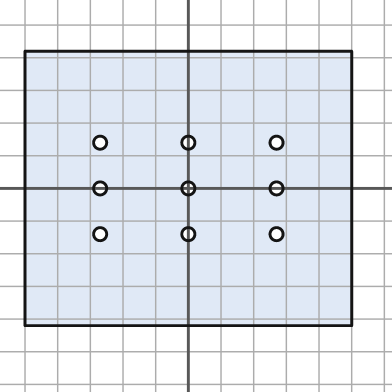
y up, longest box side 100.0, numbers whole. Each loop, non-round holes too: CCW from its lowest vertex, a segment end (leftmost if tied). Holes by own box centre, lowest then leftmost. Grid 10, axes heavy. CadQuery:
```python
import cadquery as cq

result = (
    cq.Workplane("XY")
    .moveTo(-50.0, -42.0)
    .lineTo(50.0, -42.0)
    .lineTo(50.0, 42.0)
    .lineTo(-50.0, 42.0)
    .close()
    .moveTo(-27.0, -14.0)
    .circle(2.0)
    .moveTo(0.0, -14.0)
    .circle(2.0)
    .moveTo(27.0, -14.0)
    .circle(2.0)
    .moveTo(-27.0, 0.0)
    .circle(2.0)
    .moveTo(0.0, 0.0)
    .circle(2.0)
    .moveTo(27.0, 0.0)
    .circle(2.0)
    .moveTo(-27.0, 14.0)
    .circle(2.0)
    .moveTo(0.0, 14.0)
    .circle(2.0)
    .moveTo(27.0, 14.0)
    .circle(2.0)
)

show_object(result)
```